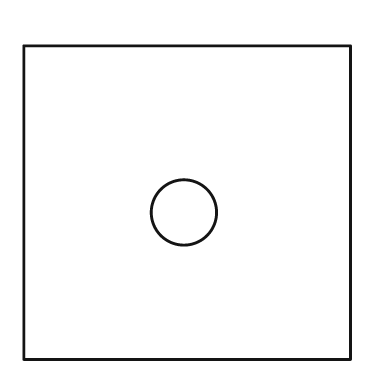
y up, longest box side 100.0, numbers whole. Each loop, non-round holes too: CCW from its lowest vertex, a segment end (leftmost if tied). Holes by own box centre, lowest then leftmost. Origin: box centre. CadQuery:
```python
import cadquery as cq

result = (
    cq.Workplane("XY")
    .moveTo(-50.0, -48.0)
    .lineTo(50.0, -48.0)
    .lineTo(50.0, 48.0)
    .lineTo(-50.0, 48.0)
    .close()
    .moveTo(-1.0, -3.0)
    .circle(10.0)
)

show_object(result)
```